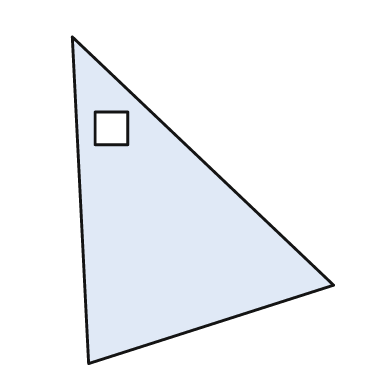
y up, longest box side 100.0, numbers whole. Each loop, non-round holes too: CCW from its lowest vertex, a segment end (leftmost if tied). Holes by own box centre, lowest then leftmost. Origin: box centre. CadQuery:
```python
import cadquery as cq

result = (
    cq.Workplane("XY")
    .moveTo(-35.0, -50.0)
    .lineTo(40.0, -26.0)
    .lineTo(-40.0, 50.0)
    .close()
    .moveTo(-33.0, 17.0)
    .lineTo(-23.0, 17.0)
    .lineTo(-23.0, 27.0)
    .lineTo(-33.0, 27.0)
    .close()
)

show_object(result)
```